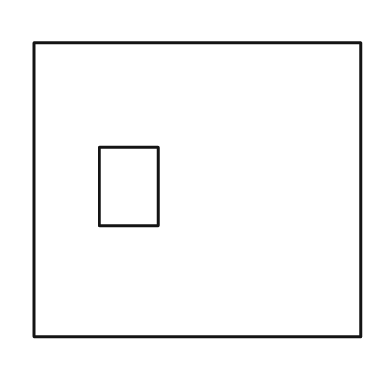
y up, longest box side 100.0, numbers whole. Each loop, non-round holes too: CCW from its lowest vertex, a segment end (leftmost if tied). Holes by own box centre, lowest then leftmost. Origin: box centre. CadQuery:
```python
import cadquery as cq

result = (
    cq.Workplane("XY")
    .moveTo(-50.0, -45.0)
    .lineTo(50.0, -45.0)
    .lineTo(50.0, 45.0)
    .lineTo(-50.0, 45.0)
    .close()
    .moveTo(-30.0, -11.0)
    .lineTo(-12.0, -11.0)
    .lineTo(-12.0, 13.0)
    .lineTo(-30.0, 13.0)
    .close()
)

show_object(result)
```